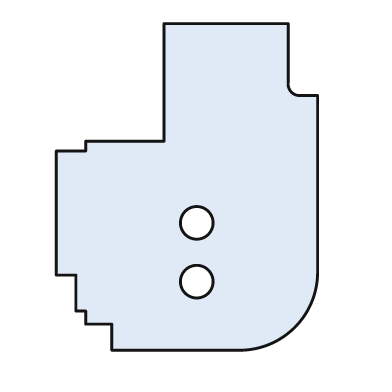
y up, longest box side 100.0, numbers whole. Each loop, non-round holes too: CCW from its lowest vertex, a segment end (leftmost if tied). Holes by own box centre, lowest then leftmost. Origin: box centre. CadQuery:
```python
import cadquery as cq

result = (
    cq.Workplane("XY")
    .moveTo(-23.0, -50.0)
    .lineTo(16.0, -50.0)
    .threePointArc((33.0, -43.0), (40.0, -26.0))
    .lineTo(40.0, 28.0)
    .lineTo(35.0, 28.0)
    .threePointArc((32.0, 29.0), (31.0, 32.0))
    .lineTo(31.0, 50.0)
    .lineTo(-7.0, 50.0)
    .lineTo(-7.0, 14.0)
    .lineTo(-31.0, 14.0)
    .lineTo(-31.0, 11.0)
    .lineTo(-40.0, 11.0)
    .lineTo(-40.0, -27.0)
    .lineTo(-34.0, -27.0)
    .lineTo(-34.0, -38.0)
    .lineTo(-31.0, -38.0)
    .lineTo(-31.0, -42.0)
    .lineTo(-23.0, -42.0)
    .close()
    .moveTo(3.0, -29.0)
    .circle(5.0)
    .moveTo(3.0, -11.0)
    .circle(5.0)
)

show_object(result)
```